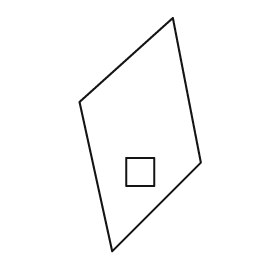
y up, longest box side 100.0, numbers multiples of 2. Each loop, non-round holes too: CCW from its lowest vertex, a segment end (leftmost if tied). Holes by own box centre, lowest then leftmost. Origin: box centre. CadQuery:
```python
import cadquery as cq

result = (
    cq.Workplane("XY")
    .moveTo(-12.0, -50.0)
    .lineTo(26.0, -12.0)
    .lineTo(14.0, 50.0)
    .lineTo(-26.0, 14.0)
    .close()
    .moveTo(-6.0, -22.0)
    .lineTo(6.0, -22.0)
    .lineTo(6.0, -10.0)
    .lineTo(-6.0, -10.0)
    .close()
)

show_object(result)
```